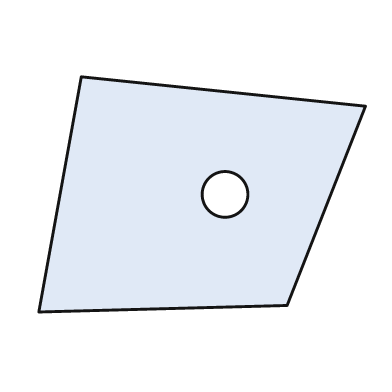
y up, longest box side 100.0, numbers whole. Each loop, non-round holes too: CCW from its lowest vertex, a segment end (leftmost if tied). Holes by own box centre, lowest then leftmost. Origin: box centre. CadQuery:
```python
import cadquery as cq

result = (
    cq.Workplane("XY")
    .moveTo(-50.0, -36.0)
    .lineTo(26.0, -34.0)
    .lineTo(50.0, 27.0)
    .lineTo(-37.0, 36.0)
    .close()
    .moveTo(7.0, 0.0)
    .circle(7.0)
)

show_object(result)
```